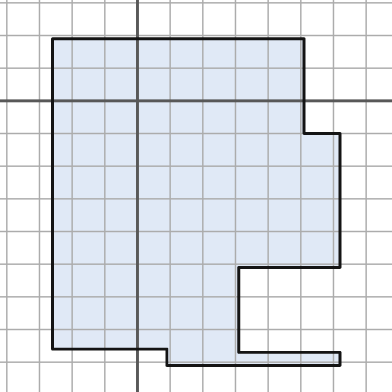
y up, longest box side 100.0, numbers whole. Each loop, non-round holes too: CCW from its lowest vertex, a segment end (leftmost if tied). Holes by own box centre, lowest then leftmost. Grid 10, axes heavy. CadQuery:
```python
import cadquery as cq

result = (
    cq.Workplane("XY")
    .moveTo(9.0, -81.0)
    .lineTo(62.0, -81.0)
    .lineTo(62.0, -77.0)
    .lineTo(31.0, -77.0)
    .lineTo(31.0, -51.0)
    .lineTo(62.0, -51.0)
    .lineTo(62.0, -10.0)
    .lineTo(51.0, -10.0)
    .lineTo(51.0, 19.0)
    .lineTo(-26.0, 19.0)
    .lineTo(-26.0, -76.0)
    .lineTo(9.0, -76.0)
    .close()
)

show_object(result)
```